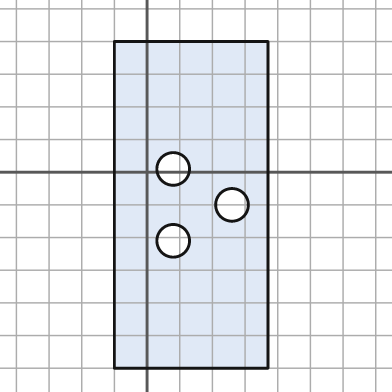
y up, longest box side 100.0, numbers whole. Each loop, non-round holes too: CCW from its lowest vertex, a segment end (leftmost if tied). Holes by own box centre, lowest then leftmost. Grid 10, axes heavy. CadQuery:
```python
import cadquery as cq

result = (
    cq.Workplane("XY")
    .moveTo(-10.0, -60.0)
    .lineTo(37.0, -60.0)
    .lineTo(37.0, 40.0)
    .lineTo(-10.0, 40.0)
    .close()
    .moveTo(8.0, -21.0)
    .circle(5.0)
    .moveTo(26.0, -10.0)
    .circle(5.0)
    .moveTo(8.0, 1.0)
    .circle(5.0)
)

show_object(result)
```